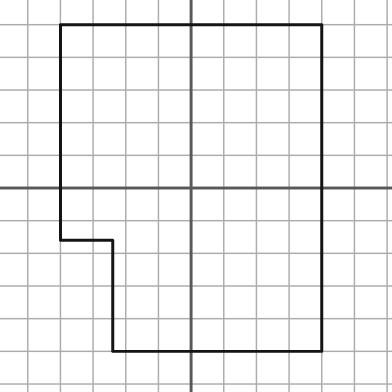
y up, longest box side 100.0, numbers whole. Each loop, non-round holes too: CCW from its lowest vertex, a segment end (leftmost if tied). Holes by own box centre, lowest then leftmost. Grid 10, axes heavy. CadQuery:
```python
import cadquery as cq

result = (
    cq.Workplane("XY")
    .moveTo(-24.0, -50.0)
    .lineTo(40.0, -50.0)
    .lineTo(40.0, 50.0)
    .lineTo(-40.0, 50.0)
    .lineTo(-40.0, -16.0)
    .lineTo(-24.0, -16.0)
    .close()
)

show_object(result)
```